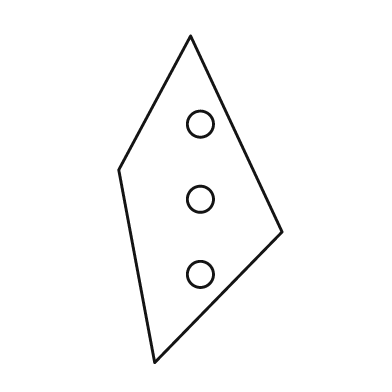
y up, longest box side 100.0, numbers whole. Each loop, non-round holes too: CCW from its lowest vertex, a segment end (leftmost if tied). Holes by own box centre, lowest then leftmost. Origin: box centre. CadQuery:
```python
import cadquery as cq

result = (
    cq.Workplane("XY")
    .moveTo(-14.0, -50.0)
    .lineTo(25.0, -10.0)
    .lineTo(-3.0, 50.0)
    .lineTo(-25.0, 9.0)
    .close()
    .moveTo(0.0, -23.0)
    .circle(4.0)
    .moveTo(0.0, 0.0)
    .circle(4.0)
    .moveTo(0.0, 23.0)
    .circle(4.0)
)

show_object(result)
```